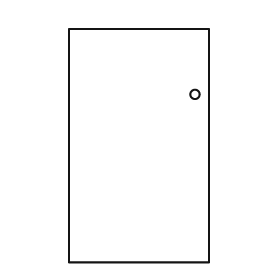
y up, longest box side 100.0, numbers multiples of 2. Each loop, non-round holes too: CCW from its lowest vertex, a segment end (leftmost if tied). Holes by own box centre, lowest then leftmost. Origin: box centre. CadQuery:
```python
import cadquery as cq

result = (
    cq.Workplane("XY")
    .moveTo(-30.0, -50.0)
    .lineTo(30.0, -50.0)
    .lineTo(30.0, 50.0)
    .lineTo(-30.0, 50.0)
    .close()
    .moveTo(24.0, 22.0)
    .circle(2.0)
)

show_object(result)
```